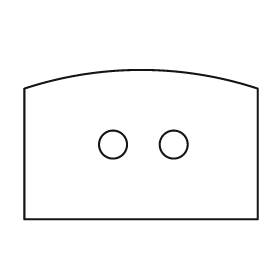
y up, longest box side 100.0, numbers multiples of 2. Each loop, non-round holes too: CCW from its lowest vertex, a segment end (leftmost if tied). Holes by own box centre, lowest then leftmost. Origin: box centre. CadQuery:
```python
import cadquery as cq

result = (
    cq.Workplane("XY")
    .moveTo(-50.0, -32.0)
    .lineTo(50.0, -32.0)
    .lineTo(50.0, 24.0)
    .threePointArc((0.0, 32.0), (-50.0, 24.0))
    .close()
    .moveTo(-12.0, 0.0)
    .circle(6.0)
    .moveTo(14.0, 0.0)
    .circle(6.0)
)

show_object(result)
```